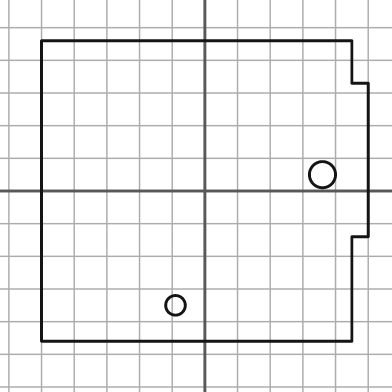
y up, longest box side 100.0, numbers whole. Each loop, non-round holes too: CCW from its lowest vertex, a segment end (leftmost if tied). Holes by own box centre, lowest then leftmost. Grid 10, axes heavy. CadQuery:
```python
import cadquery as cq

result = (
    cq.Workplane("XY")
    .moveTo(-50.0, -46.0)
    .lineTo(45.0, -46.0)
    .lineTo(45.0, -14.0)
    .lineTo(50.0, -14.0)
    .lineTo(50.0, 33.0)
    .lineTo(45.0, 33.0)
    .lineTo(45.0, 46.0)
    .lineTo(-50.0, 46.0)
    .close()
    .moveTo(-9.0, -35.0)
    .circle(3.0)
    .moveTo(36.0, 5.0)
    .circle(4.0)
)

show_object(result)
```